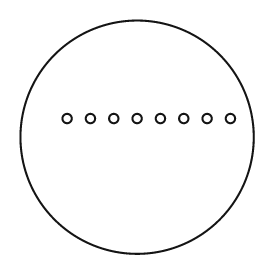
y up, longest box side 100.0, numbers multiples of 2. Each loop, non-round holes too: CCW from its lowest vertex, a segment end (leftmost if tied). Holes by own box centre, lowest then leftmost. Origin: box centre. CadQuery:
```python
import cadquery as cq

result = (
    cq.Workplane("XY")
    .moveTo(0.0, 0.0)
    .circle(50.0)
    .moveTo(-30.0, 8.0)
    .circle(2.0)
    .moveTo(-20.0, 8.0)
    .circle(2.0)
    .moveTo(-10.0, 8.0)
    .circle(2.0)
    .moveTo(0.0, 8.0)
    .circle(2.0)
    .moveTo(10.0, 8.0)
    .circle(2.0)
    .moveTo(20.0, 8.0)
    .circle(2.0)
    .moveTo(30.0, 8.0)
    .circle(2.0)
    .moveTo(40.0, 8.0)
    .circle(2.0)
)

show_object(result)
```